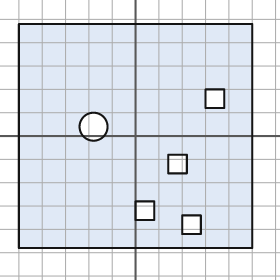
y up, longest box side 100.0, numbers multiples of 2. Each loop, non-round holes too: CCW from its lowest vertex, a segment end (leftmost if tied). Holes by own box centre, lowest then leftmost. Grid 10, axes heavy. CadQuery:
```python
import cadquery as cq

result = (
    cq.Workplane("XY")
    .moveTo(-50.0, -48.0)
    .lineTo(50.0, -48.0)
    .lineTo(50.0, 48.0)
    .lineTo(-50.0, 48.0)
    .close()
    .moveTo(20.0, -42.0)
    .lineTo(28.0, -42.0)
    .lineTo(28.0, -34.0)
    .lineTo(20.0, -34.0)
    .close()
    .moveTo(0.0, -36.0)
    .lineTo(8.0, -36.0)
    .lineTo(8.0, -28.0)
    .lineTo(0.0, -28.0)
    .close()
    .moveTo(14.0, -16.0)
    .lineTo(22.0, -16.0)
    .lineTo(22.0, -8.0)
    .lineTo(14.0, -8.0)
    .close()
    .moveTo(-18.0, 4.0)
    .circle(6.0)
    .moveTo(30.0, 12.0)
    .lineTo(38.0, 12.0)
    .lineTo(38.0, 20.0)
    .lineTo(30.0, 20.0)
    .close()
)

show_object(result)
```